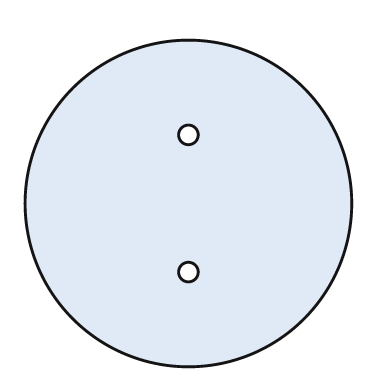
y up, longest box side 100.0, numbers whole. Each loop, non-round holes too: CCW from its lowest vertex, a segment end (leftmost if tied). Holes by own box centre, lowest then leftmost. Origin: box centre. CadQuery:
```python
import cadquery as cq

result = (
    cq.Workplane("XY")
    .moveTo(0.0, 0.0)
    .circle(50.0)
    .moveTo(0.0, -21.0)
    .circle(3.0)
    .moveTo(0.0, 21.0)
    .circle(3.0)
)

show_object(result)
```